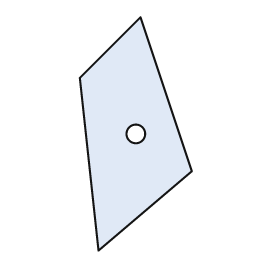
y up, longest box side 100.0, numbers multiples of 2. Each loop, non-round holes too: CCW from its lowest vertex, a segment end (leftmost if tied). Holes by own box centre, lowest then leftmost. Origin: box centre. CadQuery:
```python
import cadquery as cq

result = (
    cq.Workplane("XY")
    .moveTo(-16.0, -50.0)
    .lineTo(24.0, -16.0)
    .lineTo(2.0, 50.0)
    .lineTo(-24.0, 24.0)
    .close()
    .moveTo(0.0, 0.0)
    .circle(4.0)
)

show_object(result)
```